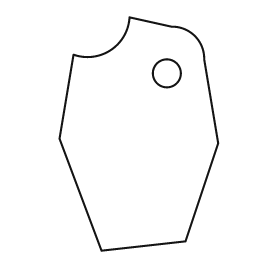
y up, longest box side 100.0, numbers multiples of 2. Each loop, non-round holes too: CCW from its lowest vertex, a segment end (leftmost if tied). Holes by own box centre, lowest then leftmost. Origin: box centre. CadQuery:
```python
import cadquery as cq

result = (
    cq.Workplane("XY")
    .moveTo(-16.0, -50.0)
    .lineTo(20.0, -46.0)
    .lineTo(34.0, -4.0)
    .lineTo(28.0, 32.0)
    .threePointArc((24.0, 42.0), (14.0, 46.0))
    .lineTo(-4.0, 50.0)
    .threePointArc((-12.0, 36.0), (-28.0, 34.0))
    .lineTo(-34.0, -2.0)
    .close()
    .moveTo(12.0, 26.0)
    .circle(6.0)
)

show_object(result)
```